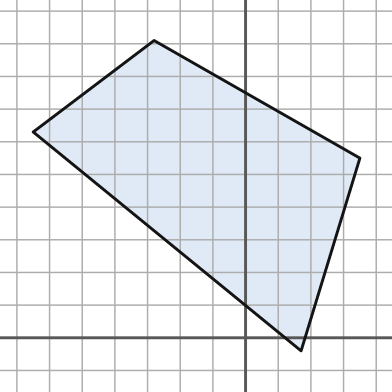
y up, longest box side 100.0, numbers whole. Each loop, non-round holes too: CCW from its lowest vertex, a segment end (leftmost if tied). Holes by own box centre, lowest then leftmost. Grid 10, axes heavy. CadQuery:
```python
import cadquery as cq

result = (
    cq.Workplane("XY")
    .moveTo(17.0, -4.0)
    .lineTo(35.0, 55.0)
    .lineTo(-28.0, 91.0)
    .lineTo(-65.0, 63.0)
    .close()
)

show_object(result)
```